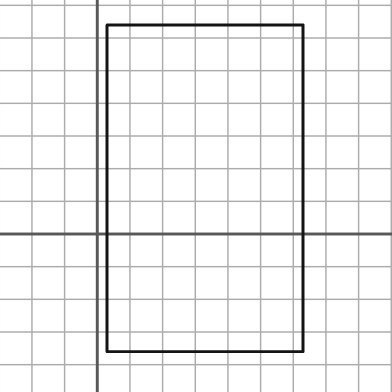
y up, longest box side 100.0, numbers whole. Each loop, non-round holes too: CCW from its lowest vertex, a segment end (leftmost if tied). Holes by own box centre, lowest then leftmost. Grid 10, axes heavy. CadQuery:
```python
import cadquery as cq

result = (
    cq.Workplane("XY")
    .moveTo(3.0, -36.0)
    .lineTo(63.0, -36.0)
    .lineTo(63.0, 64.0)
    .lineTo(3.0, 64.0)
    .close()
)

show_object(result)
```